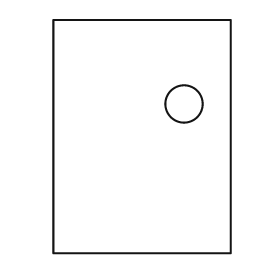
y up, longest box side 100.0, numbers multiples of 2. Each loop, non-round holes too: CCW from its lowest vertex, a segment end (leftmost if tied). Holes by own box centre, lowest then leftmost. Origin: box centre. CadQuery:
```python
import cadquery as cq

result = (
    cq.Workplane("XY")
    .moveTo(-38.0, -50.0)
    .lineTo(38.0, -50.0)
    .lineTo(38.0, 50.0)
    .lineTo(-38.0, 50.0)
    .close()
    .moveTo(18.0, 14.0)
    .circle(8.0)
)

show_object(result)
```